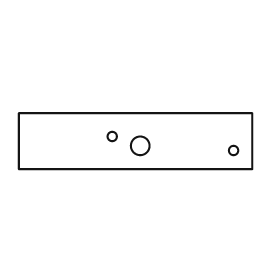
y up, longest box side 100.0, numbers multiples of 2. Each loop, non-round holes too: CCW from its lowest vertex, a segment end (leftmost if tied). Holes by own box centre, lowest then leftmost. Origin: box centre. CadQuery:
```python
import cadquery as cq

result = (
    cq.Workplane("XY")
    .moveTo(-50.0, -12.0)
    .lineTo(50.0, -12.0)
    .lineTo(50.0, 12.0)
    .lineTo(-50.0, 12.0)
    .close()
    .moveTo(42.0, -4.0)
    .circle(2.0)
    .moveTo(2.0, -2.0)
    .circle(4.0)
    .moveTo(-10.0, 2.0)
    .circle(2.0)
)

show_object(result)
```